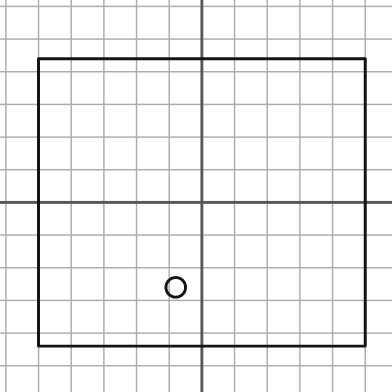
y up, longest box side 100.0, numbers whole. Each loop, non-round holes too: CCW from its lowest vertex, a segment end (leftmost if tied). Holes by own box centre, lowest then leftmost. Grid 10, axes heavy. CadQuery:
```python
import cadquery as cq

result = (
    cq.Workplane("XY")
    .moveTo(-50.0, -44.0)
    .lineTo(50.0, -44.0)
    .lineTo(50.0, 44.0)
    .lineTo(-50.0, 44.0)
    .close()
    .moveTo(-8.0, -26.0)
    .circle(3.0)
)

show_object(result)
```